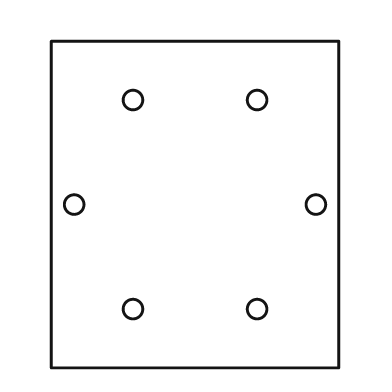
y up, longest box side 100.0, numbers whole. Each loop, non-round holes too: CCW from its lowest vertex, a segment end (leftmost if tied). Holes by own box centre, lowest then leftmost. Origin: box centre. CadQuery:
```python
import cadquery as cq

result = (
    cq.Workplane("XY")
    .moveTo(-44.0, -50.0)
    .lineTo(44.0, -50.0)
    .lineTo(44.0, 50.0)
    .lineTo(-44.0, 50.0)
    .close()
    .moveTo(-19.0, -32.0)
    .circle(3.0)
    .moveTo(19.0, -32.0)
    .circle(3.0)
    .moveTo(-37.0, 0.0)
    .circle(3.0)
    .moveTo(37.0, 0.0)
    .circle(3.0)
    .moveTo(-19.0, 32.0)
    .circle(3.0)
    .moveTo(19.0, 32.0)
    .circle(3.0)
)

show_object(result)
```